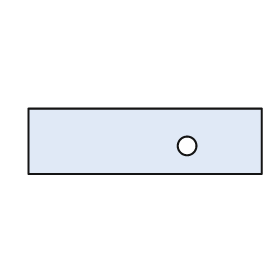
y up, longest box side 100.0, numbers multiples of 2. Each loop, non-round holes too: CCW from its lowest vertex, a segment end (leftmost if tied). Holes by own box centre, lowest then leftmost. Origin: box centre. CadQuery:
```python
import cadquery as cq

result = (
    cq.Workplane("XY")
    .moveTo(-50.0, -14.0)
    .lineTo(50.0, -14.0)
    .lineTo(50.0, 14.0)
    .lineTo(-50.0, 14.0)
    .close()
    .moveTo(18.0, -2.0)
    .circle(4.0)
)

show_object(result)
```